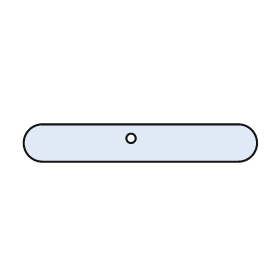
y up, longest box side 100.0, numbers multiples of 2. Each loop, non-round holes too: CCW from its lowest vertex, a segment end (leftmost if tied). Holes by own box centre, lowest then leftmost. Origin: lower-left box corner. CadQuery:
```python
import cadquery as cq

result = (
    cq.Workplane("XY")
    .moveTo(8.0, 0.0)
    .lineTo(92.0, 0.0)
    .threePointArc((100.0, 8.0), (92.0, 16.0))
    .lineTo(8.0, 16.0)
    .threePointArc((0.0, 8.0), (8.0, 0.0))
    .close()
    .moveTo(46.0, 10.0)
    .circle(2.0)
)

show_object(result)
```